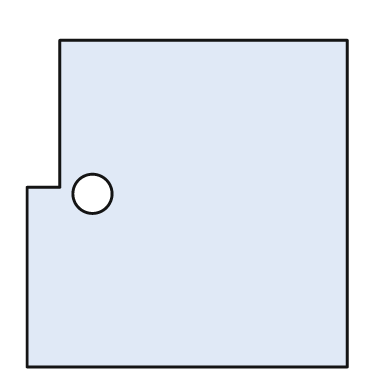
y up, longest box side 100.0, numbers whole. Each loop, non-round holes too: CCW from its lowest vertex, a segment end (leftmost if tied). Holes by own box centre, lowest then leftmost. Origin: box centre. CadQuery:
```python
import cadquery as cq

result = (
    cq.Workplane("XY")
    .moveTo(-49.0, -50.0)
    .lineTo(49.0, -50.0)
    .lineTo(49.0, 50.0)
    .lineTo(-39.0, 50.0)
    .lineTo(-39.0, 5.0)
    .lineTo(-49.0, 5.0)
    .close()
    .moveTo(-29.0, 3.0)
    .circle(6.0)
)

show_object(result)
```